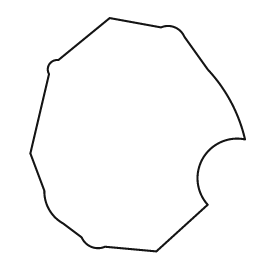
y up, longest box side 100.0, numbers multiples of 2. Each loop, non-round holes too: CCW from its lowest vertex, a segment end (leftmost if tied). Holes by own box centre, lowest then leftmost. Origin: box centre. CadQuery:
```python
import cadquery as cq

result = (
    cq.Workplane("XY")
    .moveTo(8.0, -50.0)
    .lineTo(30.0, -30.0)
    .threePointArc((28.0, -10.0), (46.0, -2.0))
    .threePointArc((40.0, 14.0), (30.0, 28.0))
    .lineTo(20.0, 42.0)
    .threePointArc((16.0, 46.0), (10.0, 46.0))
    .lineTo(-12.0, 50.0)
    .lineTo(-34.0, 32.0)
    .threePointArc((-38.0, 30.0), (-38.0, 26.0))
    .lineTo(-46.0, -8.0)
    .lineTo(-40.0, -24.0)
    .threePointArc((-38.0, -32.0), (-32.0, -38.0))
    .lineTo(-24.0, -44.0)
    .threePointArc((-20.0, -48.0), (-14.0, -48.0))
    .close()
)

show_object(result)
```